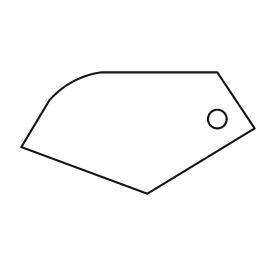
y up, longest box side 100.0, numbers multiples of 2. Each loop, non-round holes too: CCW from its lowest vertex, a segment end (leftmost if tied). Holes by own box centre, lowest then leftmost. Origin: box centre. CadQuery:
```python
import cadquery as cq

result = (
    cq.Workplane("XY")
    .moveTo(4.0, -26.0)
    .lineTo(50.0, 2.0)
    .lineTo(34.0, 26.0)
    .lineTo(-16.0, 26.0)
    .threePointArc((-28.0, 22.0), (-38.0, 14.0))
    .lineTo(-50.0, -6.0)
    .close()
    .moveTo(34.0, 6.0)
    .circle(4.0)
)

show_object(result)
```